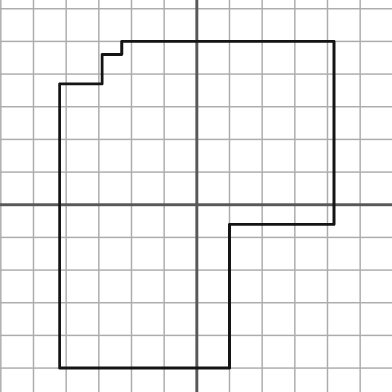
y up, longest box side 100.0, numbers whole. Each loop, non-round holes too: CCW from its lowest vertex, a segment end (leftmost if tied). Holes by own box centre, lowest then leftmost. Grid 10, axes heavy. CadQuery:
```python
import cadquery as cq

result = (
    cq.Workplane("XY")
    .moveTo(-42.0, -50.0)
    .lineTo(10.0, -50.0)
    .lineTo(10.0, -6.0)
    .lineTo(42.0, -6.0)
    .lineTo(42.0, 50.0)
    .lineTo(-23.0, 50.0)
    .lineTo(-23.0, 46.0)
    .lineTo(-29.0, 46.0)
    .lineTo(-29.0, 37.0)
    .lineTo(-42.0, 37.0)
    .close()
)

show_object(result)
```